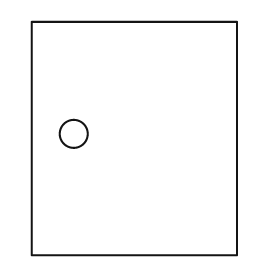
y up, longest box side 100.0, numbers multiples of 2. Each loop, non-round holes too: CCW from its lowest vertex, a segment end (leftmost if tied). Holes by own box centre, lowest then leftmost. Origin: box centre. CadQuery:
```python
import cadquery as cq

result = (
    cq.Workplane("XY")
    .moveTo(-44.0, -50.0)
    .lineTo(44.0, -50.0)
    .lineTo(44.0, 50.0)
    .lineTo(-44.0, 50.0)
    .close()
    .moveTo(-26.0, 2.0)
    .circle(6.0)
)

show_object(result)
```